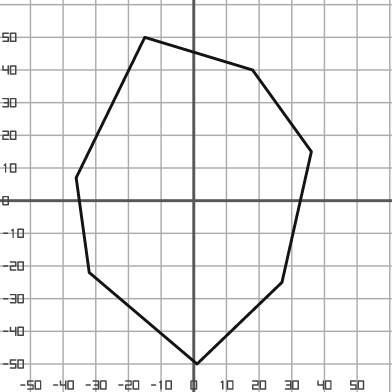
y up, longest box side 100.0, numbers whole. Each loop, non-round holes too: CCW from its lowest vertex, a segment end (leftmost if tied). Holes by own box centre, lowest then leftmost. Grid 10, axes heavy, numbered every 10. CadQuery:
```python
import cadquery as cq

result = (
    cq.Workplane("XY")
    .moveTo(1.0, -50.0)
    .lineTo(27.0, -25.0)
    .lineTo(36.0, 15.0)
    .lineTo(18.0, 40.0)
    .lineTo(-15.0, 50.0)
    .lineTo(-36.0, 7.0)
    .lineTo(-32.0, -22.0)
    .close()
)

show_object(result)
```